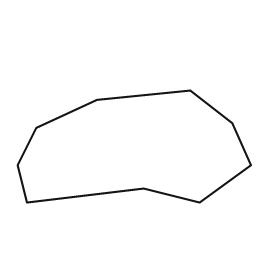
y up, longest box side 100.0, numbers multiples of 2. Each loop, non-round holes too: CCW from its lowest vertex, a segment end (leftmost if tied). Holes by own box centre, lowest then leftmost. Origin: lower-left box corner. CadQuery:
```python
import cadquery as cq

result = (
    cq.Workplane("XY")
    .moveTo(4.0, 0.0)
    .lineTo(54.0, 6.0)
    .lineTo(78.0, 0.0)
    .lineTo(100.0, 16.0)
    .lineTo(92.0, 34.0)
    .lineTo(74.0, 48.0)
    .lineTo(34.0, 44.0)
    .lineTo(8.0, 32.0)
    .lineTo(0.0, 16.0)
    .close()
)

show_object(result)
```